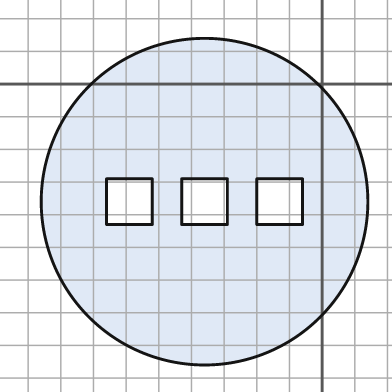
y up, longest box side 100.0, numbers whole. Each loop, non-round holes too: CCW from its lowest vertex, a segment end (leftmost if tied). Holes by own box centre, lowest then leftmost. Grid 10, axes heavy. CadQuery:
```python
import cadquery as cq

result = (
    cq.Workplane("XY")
    .moveTo(-36.0, -36.0)
    .circle(50.0)
    .moveTo(-66.0, -43.0)
    .lineTo(-52.0, -43.0)
    .lineTo(-52.0, -29.0)
    .lineTo(-66.0, -29.0)
    .close()
    .moveTo(-43.0, -43.0)
    .lineTo(-29.0, -43.0)
    .lineTo(-29.0, -29.0)
    .lineTo(-43.0, -29.0)
    .close()
    .moveTo(-20.0, -43.0)
    .lineTo(-6.0, -43.0)
    .lineTo(-6.0, -29.0)
    .lineTo(-20.0, -29.0)
    .close()
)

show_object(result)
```